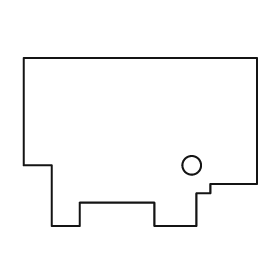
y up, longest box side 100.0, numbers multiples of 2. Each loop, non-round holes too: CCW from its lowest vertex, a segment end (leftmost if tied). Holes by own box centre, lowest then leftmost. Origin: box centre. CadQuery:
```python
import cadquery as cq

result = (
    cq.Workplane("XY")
    .moveTo(-38.0, -36.0)
    .lineTo(-26.0, -36.0)
    .lineTo(-26.0, -26.0)
    .lineTo(6.0, -26.0)
    .lineTo(6.0, -36.0)
    .lineTo(24.0, -36.0)
    .lineTo(24.0, -22.0)
    .lineTo(30.0, -22.0)
    .lineTo(30.0, -18.0)
    .lineTo(50.0, -18.0)
    .lineTo(50.0, 36.0)
    .lineTo(-50.0, 36.0)
    .lineTo(-50.0, -10.0)
    .lineTo(-38.0, -10.0)
    .close()
    .moveTo(22.0, -10.0)
    .circle(4.0)
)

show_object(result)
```